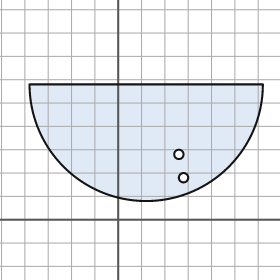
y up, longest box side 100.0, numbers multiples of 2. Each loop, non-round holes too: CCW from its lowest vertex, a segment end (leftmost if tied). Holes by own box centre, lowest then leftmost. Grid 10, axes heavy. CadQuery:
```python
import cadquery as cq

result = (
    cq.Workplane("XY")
    .moveTo(-38.0, 58.0)
    .threePointArc((12.0, 8.0), (62.0, 58.0))
    .close()
    .moveTo(28.0, 18.0)
    .circle(2.0)
    .moveTo(26.0, 28.0)
    .circle(2.0)
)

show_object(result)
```